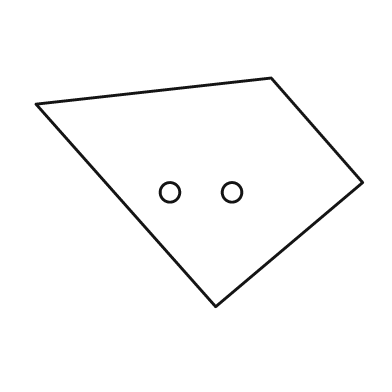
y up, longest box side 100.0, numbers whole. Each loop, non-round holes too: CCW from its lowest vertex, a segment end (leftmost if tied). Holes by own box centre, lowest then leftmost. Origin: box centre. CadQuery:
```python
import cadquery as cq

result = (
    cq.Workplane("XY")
    .moveTo(5.0, -35.0)
    .lineTo(50.0, 3.0)
    .lineTo(22.0, 35.0)
    .lineTo(-50.0, 27.0)
    .close()
    .moveTo(-9.0, 0.0)
    .circle(3.0)
    .moveTo(10.0, 0.0)
    .circle(3.0)
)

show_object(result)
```